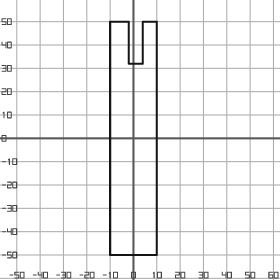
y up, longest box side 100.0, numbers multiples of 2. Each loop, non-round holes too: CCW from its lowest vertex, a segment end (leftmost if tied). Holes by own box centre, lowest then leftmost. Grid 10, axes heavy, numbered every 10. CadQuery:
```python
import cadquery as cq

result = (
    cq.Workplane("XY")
    .moveTo(-10.0, -50.0)
    .lineTo(10.0, -50.0)
    .lineTo(10.0, 50.0)
    .lineTo(4.0, 50.0)
    .lineTo(4.0, 32.0)
    .lineTo(-2.0, 32.0)
    .lineTo(-2.0, 50.0)
    .lineTo(-10.0, 50.0)
    .close()
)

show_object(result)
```